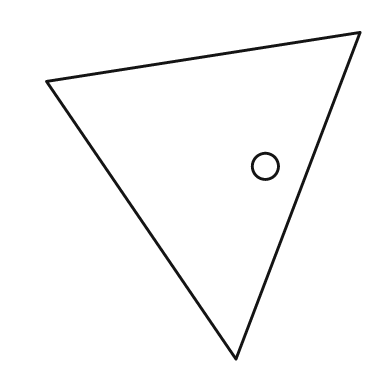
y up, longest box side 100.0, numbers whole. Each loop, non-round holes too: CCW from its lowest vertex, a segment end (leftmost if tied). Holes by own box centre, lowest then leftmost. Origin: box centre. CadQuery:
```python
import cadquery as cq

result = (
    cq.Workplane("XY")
    .moveTo(10.0, -50.0)
    .lineTo(48.0, 50.0)
    .lineTo(-48.0, 35.0)
    .close()
    .moveTo(19.0, 9.0)
    .circle(4.0)
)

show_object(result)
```